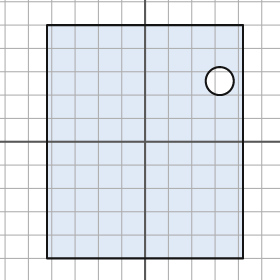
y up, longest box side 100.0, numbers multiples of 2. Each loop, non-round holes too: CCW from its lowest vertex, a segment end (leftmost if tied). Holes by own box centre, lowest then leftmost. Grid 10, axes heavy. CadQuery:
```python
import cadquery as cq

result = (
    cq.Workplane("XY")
    .moveTo(-42.0, -50.0)
    .lineTo(42.0, -50.0)
    .lineTo(42.0, 50.0)
    .lineTo(-42.0, 50.0)
    .close()
    .moveTo(32.0, 26.0)
    .circle(6.0)
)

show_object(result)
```